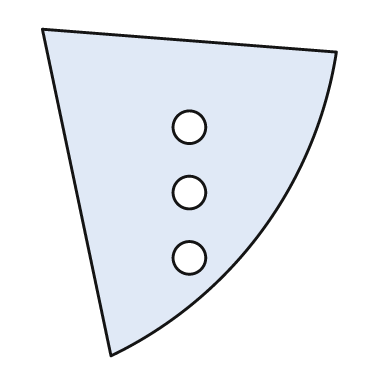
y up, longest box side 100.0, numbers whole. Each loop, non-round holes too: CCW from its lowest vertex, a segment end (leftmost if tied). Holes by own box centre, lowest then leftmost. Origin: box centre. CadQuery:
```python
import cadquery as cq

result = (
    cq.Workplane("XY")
    .moveTo(-24.0, -50.0)
    .threePointArc((22.0, -12.0), (45.0, 43.0))
    .lineTo(-45.0, 50.0)
    .close()
    .moveTo(0.0, -20.0)
    .circle(5.0)
    .moveTo(0.0, 0.0)
    .circle(5.0)
    .moveTo(0.0, 20.0)
    .circle(5.0)
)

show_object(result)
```